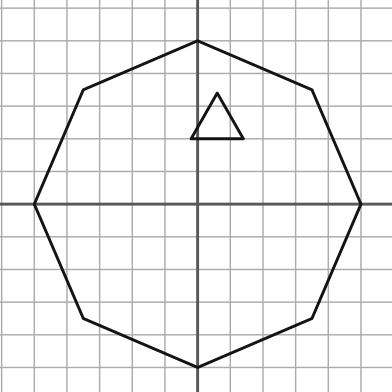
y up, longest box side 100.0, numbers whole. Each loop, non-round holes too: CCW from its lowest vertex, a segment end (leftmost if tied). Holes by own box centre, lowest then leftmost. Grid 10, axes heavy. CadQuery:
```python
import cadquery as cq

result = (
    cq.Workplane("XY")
    .moveTo(0.0, -50.0)
    .lineTo(35.0, -35.0)
    .lineTo(50.0, 0.0)
    .lineTo(35.0, 35.0)
    .lineTo(0.0, 50.0)
    .lineTo(-35.0, 35.0)
    .lineTo(-50.0, 0.0)
    .lineTo(-35.0, -35.0)
    .close()
    .moveTo(-2.0, 20.0)
    .lineTo(14.0, 20.0)
    .lineTo(6.0, 34.0)
    .close()
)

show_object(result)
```